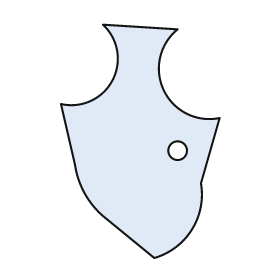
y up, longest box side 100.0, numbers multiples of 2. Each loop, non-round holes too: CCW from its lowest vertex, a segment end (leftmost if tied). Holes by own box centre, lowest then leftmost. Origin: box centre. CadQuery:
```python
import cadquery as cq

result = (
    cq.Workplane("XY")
    .moveTo(6.0, -50.0)
    .threePointArc((22.0, -38.0), (26.0, -18.0))
    .lineTo(34.0, 10.0)
    .threePointArc((10.0, 22.0), (16.0, 48.0))
    .lineTo(-16.0, 50.0)
    .threePointArc((-12.0, 26.0), (-34.0, 16.0))
    .lineTo(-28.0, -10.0)
    .threePointArc((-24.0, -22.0), (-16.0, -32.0))
    .close()
    .moveTo(16.0, -4.0)
    .circle(4.0)
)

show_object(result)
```